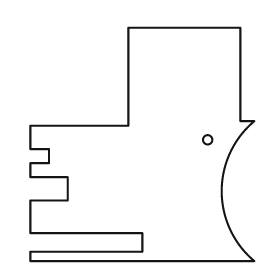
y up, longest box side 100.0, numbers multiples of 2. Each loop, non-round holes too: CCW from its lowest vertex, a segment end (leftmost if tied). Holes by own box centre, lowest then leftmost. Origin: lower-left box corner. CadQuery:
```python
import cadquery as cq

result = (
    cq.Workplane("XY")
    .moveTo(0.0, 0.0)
    .lineTo(96.0, 0.0)
    .threePointArc((82.0, 30.0), (96.0, 60.0))
    .lineTo(90.0, 60.0)
    .lineTo(90.0, 100.0)
    .lineTo(42.0, 100.0)
    .lineTo(42.0, 58.0)
    .lineTo(0.0, 58.0)
    .lineTo(0.0, 48.0)
    .lineTo(8.0, 48.0)
    .lineTo(8.0, 42.0)
    .lineTo(0.0, 42.0)
    .lineTo(0.0, 36.0)
    .lineTo(16.0, 36.0)
    .lineTo(16.0, 26.0)
    .lineTo(0.0, 26.0)
    .lineTo(0.0, 12.0)
    .lineTo(48.0, 12.0)
    .lineTo(48.0, 4.0)
    .lineTo(0.0, 4.0)
    .close()
    .moveTo(76.0, 52.0)
    .circle(2.0)
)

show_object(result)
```